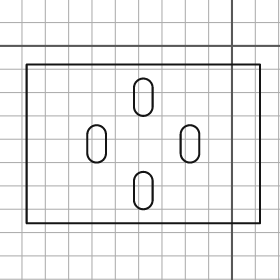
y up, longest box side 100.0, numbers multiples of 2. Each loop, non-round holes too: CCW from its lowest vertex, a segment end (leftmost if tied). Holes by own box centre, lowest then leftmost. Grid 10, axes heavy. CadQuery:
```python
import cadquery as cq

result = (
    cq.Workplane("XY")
    .moveTo(-88.0, -76.0)
    .lineTo(12.0, -76.0)
    .lineTo(12.0, -8.0)
    .lineTo(-88.0, -8.0)
    .close()
    .moveTo(-42.0, -66.0)
    .threePointArc((-38.0, -70.0), (-34.0, -66.0))
    .lineTo(-34.0, -58.0)
    .threePointArc((-38.0, -54.0), (-42.0, -58.0))
    .close()
    .moveTo(-62.0, -46.0)
    .threePointArc((-58.0, -50.0), (-54.0, -46.0))
    .lineTo(-54.0, -38.0)
    .threePointArc((-58.0, -34.0), (-62.0, -38.0))
    .close()
    .moveTo(-22.0, -46.0)
    .threePointArc((-18.0, -50.0), (-14.0, -46.0))
    .lineTo(-14.0, -38.0)
    .threePointArc((-18.0, -34.0), (-22.0, -38.0))
    .close()
    .moveTo(-42.0, -26.0)
    .threePointArc((-38.0, -30.0), (-34.0, -26.0))
    .lineTo(-34.0, -18.0)
    .threePointArc((-38.0, -14.0), (-42.0, -18.0))
    .close()
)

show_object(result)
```